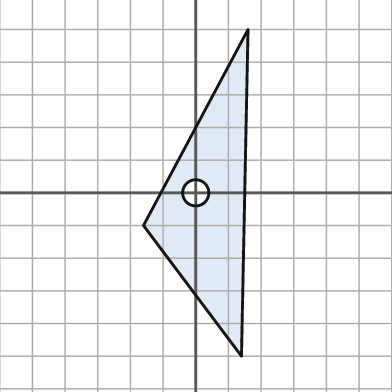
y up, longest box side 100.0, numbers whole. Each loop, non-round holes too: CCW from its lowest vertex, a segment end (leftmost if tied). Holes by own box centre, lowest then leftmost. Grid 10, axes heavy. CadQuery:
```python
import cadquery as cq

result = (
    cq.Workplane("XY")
    .moveTo(14.0, -50.0)
    .lineTo(16.0, 50.0)
    .lineTo(-16.0, -10.0)
    .close()
    .moveTo(0.0, 0.0)
    .circle(4.0)
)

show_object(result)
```